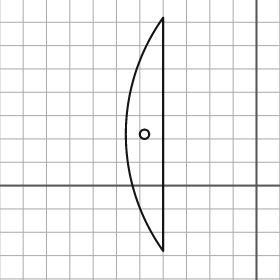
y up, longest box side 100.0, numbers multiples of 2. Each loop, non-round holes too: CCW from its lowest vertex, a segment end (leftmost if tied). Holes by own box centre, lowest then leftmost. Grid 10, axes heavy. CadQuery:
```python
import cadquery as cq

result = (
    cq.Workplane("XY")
    .moveTo(-40.0, -28.0)
    .lineTo(-40.0, 72.0)
    .threePointArc((-56.0, 22.0), (-40.0, -28.0))
    .close()
    .moveTo(-48.0, 22.0)
    .circle(2.0)
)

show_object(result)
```